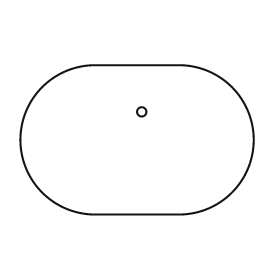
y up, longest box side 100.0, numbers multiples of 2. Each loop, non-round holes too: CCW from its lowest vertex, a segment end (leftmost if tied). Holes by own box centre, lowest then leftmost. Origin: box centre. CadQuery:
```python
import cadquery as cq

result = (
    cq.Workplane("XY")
    .moveTo(-18.0, -32.0)
    .lineTo(18.0, -32.0)
    .threePointArc((50.0, 0.0), (18.0, 32.0))
    .lineTo(-18.0, 32.0)
    .threePointArc((-50.0, 0.0), (-18.0, -32.0))
    .close()
    .moveTo(2.0, 12.0)
    .circle(2.0)
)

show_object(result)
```